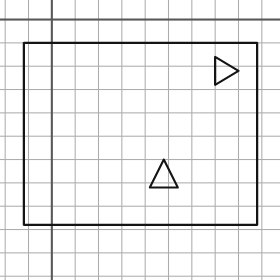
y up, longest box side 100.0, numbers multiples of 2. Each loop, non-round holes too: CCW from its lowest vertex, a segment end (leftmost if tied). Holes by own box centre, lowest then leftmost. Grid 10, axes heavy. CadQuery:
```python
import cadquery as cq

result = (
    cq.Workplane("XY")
    .moveTo(-12.0, -88.0)
    .lineTo(88.0, -88.0)
    .lineTo(88.0, -10.0)
    .lineTo(-12.0, -10.0)
    .close()
    .moveTo(42.0, -72.0)
    .lineTo(54.0, -72.0)
    .lineTo(48.0, -60.0)
    .close()
    .moveTo(70.0, -28.0)
    .lineTo(80.0, -22.0)
    .lineTo(70.0, -16.0)
    .close()
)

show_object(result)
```